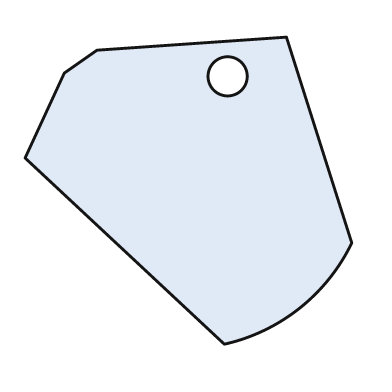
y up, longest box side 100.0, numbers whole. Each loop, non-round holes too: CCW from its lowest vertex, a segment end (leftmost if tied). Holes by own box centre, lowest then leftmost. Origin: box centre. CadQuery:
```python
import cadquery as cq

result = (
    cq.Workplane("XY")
    .moveTo(11.0, -47.0)
    .threePointArc((34.0, -36.0), (50.0, -16.0))
    .lineTo(30.0, 47.0)
    .lineTo(-28.0, 43.0)
    .lineTo(-38.0, 36.0)
    .lineTo(-50.0, 10.0)
    .close()
    .moveTo(12.0, 35.0)
    .circle(6.0)
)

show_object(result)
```